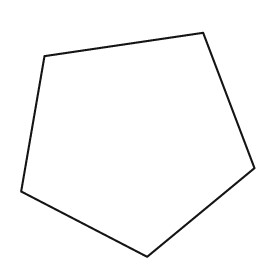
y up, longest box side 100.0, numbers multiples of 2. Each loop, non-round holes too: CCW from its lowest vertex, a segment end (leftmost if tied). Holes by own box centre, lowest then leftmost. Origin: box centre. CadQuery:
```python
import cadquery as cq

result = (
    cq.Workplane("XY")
    .moveTo(4.0, -48.0)
    .lineTo(50.0, -10.0)
    .lineTo(28.0, 48.0)
    .lineTo(-40.0, 38.0)
    .lineTo(-50.0, -20.0)
    .close()
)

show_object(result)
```